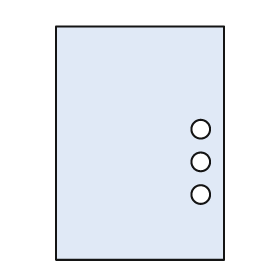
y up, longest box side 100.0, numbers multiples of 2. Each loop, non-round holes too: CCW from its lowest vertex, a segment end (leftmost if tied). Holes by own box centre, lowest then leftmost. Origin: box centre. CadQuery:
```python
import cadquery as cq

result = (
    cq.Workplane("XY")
    .moveTo(-36.0, -50.0)
    .lineTo(36.0, -50.0)
    .lineTo(36.0, 50.0)
    .lineTo(-36.0, 50.0)
    .close()
    .moveTo(26.0, -22.0)
    .circle(4.0)
    .moveTo(26.0, -8.0)
    .circle(4.0)
    .moveTo(26.0, 6.0)
    .circle(4.0)
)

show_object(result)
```